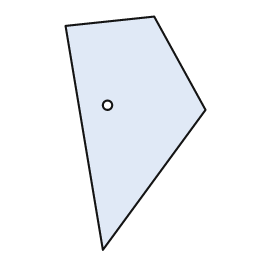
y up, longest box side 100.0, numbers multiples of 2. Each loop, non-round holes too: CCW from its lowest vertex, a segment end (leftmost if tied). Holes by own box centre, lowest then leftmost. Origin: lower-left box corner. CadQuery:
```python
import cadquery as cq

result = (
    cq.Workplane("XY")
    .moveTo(16.0, 0.0)
    .lineTo(60.0, 60.0)
    .lineTo(38.0, 100.0)
    .lineTo(0.0, 96.0)
    .close()
    .moveTo(18.0, 62.0)
    .circle(2.0)
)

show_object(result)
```